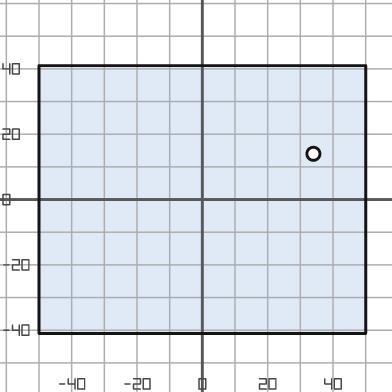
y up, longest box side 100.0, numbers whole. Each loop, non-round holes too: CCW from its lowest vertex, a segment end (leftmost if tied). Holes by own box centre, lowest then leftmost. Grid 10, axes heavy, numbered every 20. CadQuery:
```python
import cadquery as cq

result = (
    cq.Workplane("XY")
    .moveTo(-50.0, -41.0)
    .lineTo(50.0, -41.0)
    .lineTo(50.0, 41.0)
    .lineTo(-50.0, 41.0)
    .close()
    .moveTo(34.0, 14.0)
    .circle(2.0)
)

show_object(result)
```